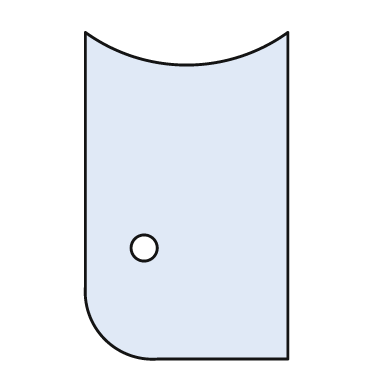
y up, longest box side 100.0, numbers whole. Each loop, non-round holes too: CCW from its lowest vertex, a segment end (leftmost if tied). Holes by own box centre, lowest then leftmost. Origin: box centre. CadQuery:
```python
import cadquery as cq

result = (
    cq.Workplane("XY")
    .moveTo(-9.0, -50.0)
    .lineTo(31.0, -50.0)
    .lineTo(31.0, 50.0)
    .threePointArc((0.0, 40.0), (-31.0, 50.0))
    .lineTo(-31.0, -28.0)
    .threePointArc((-25.0, -44.0), (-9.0, -50.0))
    .close()
    .moveTo(-13.0, -16.0)
    .circle(4.0)
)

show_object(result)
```